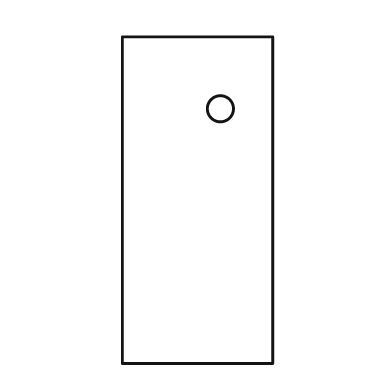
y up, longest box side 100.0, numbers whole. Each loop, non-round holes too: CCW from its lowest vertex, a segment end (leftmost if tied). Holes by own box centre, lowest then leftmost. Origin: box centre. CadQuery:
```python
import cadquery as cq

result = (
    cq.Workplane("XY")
    .moveTo(-23.0, -50.0)
    .lineTo(23.0, -50.0)
    .lineTo(23.0, 50.0)
    .lineTo(-23.0, 50.0)
    .close()
    .moveTo(7.0, 28.0)
    .circle(4.0)
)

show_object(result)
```